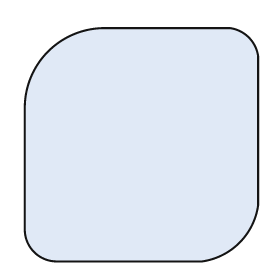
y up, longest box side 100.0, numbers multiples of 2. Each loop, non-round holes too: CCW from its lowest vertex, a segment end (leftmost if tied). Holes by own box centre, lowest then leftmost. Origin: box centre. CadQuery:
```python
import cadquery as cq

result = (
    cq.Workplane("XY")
    .moveTo(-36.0, -50.0)
    .lineTo(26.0, -50.0)
    .threePointArc((42.0, -42.0), (50.0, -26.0))
    .lineTo(50.0, 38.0)
    .threePointArc((46.0, 46.0), (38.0, 50.0))
    .lineTo(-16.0, 50.0)
    .threePointArc((-40.0, 40.0), (-50.0, 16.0))
    .lineTo(-50.0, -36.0)
    .threePointArc((-46.0, -46.0), (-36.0, -50.0))
    .close()
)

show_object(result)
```